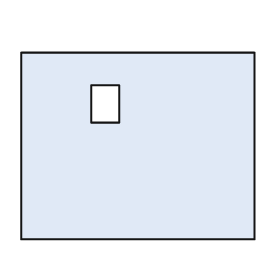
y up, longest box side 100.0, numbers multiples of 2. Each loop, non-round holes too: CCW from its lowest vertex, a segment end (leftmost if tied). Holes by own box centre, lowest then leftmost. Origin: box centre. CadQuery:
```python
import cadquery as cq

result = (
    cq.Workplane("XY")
    .moveTo(-50.0, -40.0)
    .lineTo(50.0, -40.0)
    .lineTo(50.0, 40.0)
    .lineTo(-50.0, 40.0)
    .close()
    .moveTo(-20.0, 10.0)
    .lineTo(-8.0, 10.0)
    .lineTo(-8.0, 26.0)
    .lineTo(-20.0, 26.0)
    .close()
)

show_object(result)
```